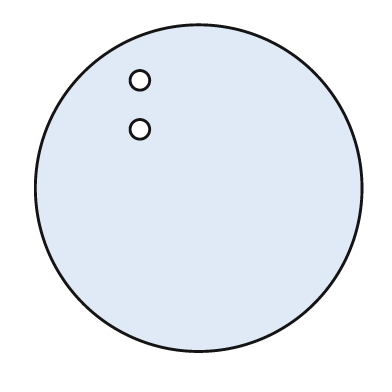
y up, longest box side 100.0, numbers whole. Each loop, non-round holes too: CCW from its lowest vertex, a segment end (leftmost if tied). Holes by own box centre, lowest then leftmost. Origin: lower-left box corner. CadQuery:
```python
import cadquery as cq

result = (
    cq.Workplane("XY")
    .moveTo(50.0, 50.0)
    .circle(50.0)
    .moveTo(32.0, 68.0)
    .circle(3.0)
    .moveTo(32.0, 83.0)
    .circle(3.0)
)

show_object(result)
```